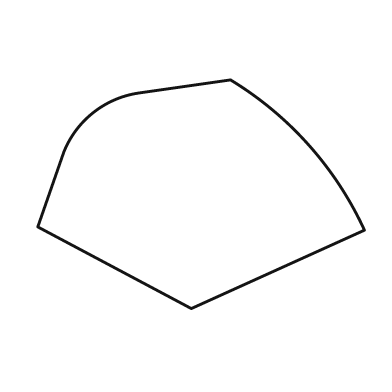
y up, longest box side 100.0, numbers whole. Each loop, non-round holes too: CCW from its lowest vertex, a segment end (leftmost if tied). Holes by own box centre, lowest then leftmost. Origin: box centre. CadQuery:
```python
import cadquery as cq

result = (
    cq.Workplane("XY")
    .moveTo(-3.0, -35.0)
    .lineTo(50.0, -11.0)
    .threePointArc((33.0, 15.0), (9.0, 35.0))
    .lineTo(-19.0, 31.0)
    .threePointArc((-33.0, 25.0), (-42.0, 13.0))
    .lineTo(-50.0, -10.0)
    .close()
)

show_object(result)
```